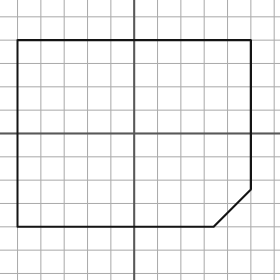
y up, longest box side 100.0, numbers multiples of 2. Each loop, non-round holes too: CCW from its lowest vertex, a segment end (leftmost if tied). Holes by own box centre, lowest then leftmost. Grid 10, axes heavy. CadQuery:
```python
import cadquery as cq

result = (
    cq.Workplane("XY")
    .moveTo(-50.0, -40.0)
    .lineTo(34.0, -40.0)
    .lineTo(50.0, -24.0)
    .lineTo(50.0, 40.0)
    .lineTo(-50.0, 40.0)
    .close()
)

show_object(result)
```